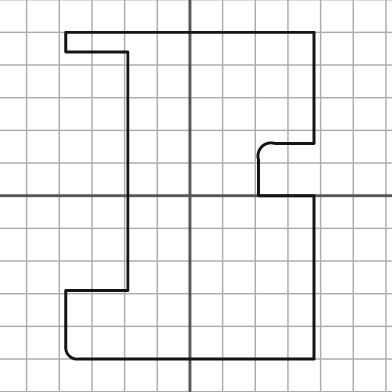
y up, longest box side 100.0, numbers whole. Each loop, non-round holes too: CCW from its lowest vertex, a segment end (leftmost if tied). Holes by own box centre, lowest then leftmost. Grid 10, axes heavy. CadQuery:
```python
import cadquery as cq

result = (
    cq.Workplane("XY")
    .moveTo(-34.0, -50.0)
    .lineTo(38.0, -50.0)
    .lineTo(38.0, 0.0)
    .lineTo(21.0, 0.0)
    .lineTo(21.0, 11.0)
    .threePointArc((22.0, 15.0), (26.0, 16.0))
    .lineTo(38.0, 16.0)
    .lineTo(38.0, 50.0)
    .lineTo(-38.0, 50.0)
    .lineTo(-38.0, 44.0)
    .lineTo(-19.0, 44.0)
    .lineTo(-19.0, -29.0)
    .lineTo(-38.0, -29.0)
    .lineTo(-38.0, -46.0)
    .threePointArc((-37.0, -49.0), (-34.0, -50.0))
    .close()
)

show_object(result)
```